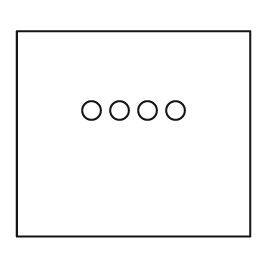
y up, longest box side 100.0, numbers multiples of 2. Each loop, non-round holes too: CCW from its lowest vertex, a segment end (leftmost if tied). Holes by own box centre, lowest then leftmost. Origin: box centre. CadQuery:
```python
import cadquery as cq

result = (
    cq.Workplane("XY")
    .moveTo(-50.0, -44.0)
    .lineTo(50.0, -44.0)
    .lineTo(50.0, 44.0)
    .lineTo(-50.0, 44.0)
    .close()
    .moveTo(-18.0, 10.0)
    .circle(4.0)
    .moveTo(-6.0, 10.0)
    .circle(4.0)
    .moveTo(6.0, 10.0)
    .circle(4.0)
    .moveTo(18.0, 10.0)
    .circle(4.0)
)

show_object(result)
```